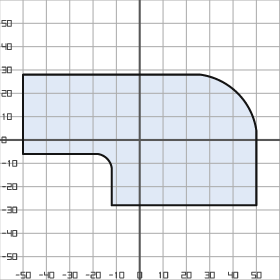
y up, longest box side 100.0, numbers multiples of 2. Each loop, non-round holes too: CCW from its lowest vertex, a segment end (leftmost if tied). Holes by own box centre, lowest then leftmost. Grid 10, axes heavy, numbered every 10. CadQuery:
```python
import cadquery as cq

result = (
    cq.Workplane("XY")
    .moveTo(-12.0, -28.0)
    .lineTo(50.0, -28.0)
    .lineTo(50.0, 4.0)
    .threePointArc((42.0, 20.0), (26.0, 28.0))
    .lineTo(-50.0, 28.0)
    .lineTo(-50.0, -6.0)
    .lineTo(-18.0, -6.0)
    .threePointArc((-14.0, -8.0), (-12.0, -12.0))
    .close()
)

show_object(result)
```